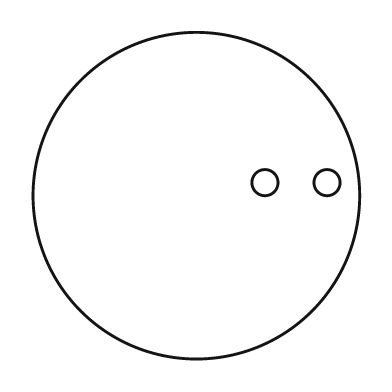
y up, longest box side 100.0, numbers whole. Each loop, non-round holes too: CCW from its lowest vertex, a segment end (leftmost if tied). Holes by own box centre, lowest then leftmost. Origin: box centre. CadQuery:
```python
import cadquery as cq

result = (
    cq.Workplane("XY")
    .moveTo(0.0, 0.0)
    .circle(50.0)
    .moveTo(21.0, 4.0)
    .circle(4.0)
    .moveTo(40.0, 4.0)
    .circle(4.0)
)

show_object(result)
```